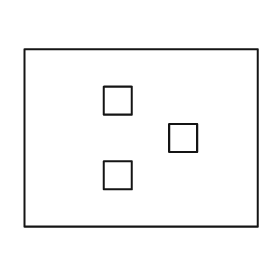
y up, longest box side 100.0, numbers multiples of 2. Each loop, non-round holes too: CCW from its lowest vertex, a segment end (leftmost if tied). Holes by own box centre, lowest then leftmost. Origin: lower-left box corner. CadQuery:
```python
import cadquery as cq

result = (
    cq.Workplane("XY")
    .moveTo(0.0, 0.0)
    .lineTo(100.0, 0.0)
    .lineTo(100.0, 76.0)
    .lineTo(0.0, 76.0)
    .close()
    .moveTo(34.0, 16.0)
    .lineTo(46.0, 16.0)
    .lineTo(46.0, 28.0)
    .lineTo(34.0, 28.0)
    .close()
    .moveTo(62.0, 32.0)
    .lineTo(74.0, 32.0)
    .lineTo(74.0, 44.0)
    .lineTo(62.0, 44.0)
    .close()
    .moveTo(34.0, 48.0)
    .lineTo(46.0, 48.0)
    .lineTo(46.0, 60.0)
    .lineTo(34.0, 60.0)
    .close()
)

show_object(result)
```